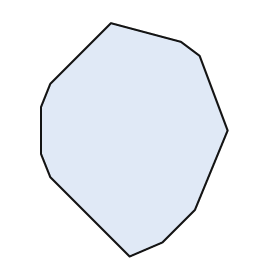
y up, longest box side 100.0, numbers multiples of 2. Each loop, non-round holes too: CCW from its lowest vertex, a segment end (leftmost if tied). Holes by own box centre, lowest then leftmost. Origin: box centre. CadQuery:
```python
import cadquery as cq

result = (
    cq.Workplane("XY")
    .moveTo(-2.0, -50.0)
    .lineTo(12.0, -44.0)
    .lineTo(26.0, -30.0)
    .lineTo(40.0, 4.0)
    .lineTo(28.0, 36.0)
    .lineTo(20.0, 42.0)
    .lineTo(-10.0, 50.0)
    .lineTo(-36.0, 24.0)
    .lineTo(-40.0, 14.0)
    .lineTo(-40.0, -6.0)
    .lineTo(-36.0, -16.0)
    .close()
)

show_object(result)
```